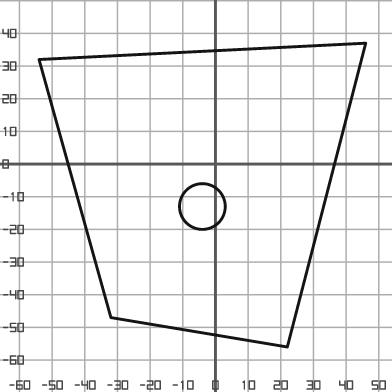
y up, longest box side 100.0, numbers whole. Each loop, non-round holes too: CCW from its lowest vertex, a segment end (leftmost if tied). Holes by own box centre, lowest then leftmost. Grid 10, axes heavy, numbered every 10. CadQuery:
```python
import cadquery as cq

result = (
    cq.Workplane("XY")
    .moveTo(22.0, -56.0)
    .lineTo(46.0, 37.0)
    .lineTo(-54.0, 32.0)
    .lineTo(-32.0, -47.0)
    .close()
    .moveTo(-4.0, -13.0)
    .circle(7.0)
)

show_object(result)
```